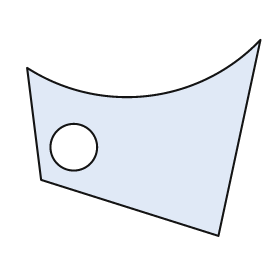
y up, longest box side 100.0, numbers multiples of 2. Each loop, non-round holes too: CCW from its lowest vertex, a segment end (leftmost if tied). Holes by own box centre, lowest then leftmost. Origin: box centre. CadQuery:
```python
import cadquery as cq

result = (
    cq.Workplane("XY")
    .moveTo(32.0, -42.0)
    .lineTo(50.0, 42.0)
    .threePointArc((2.0, 18.0), (-50.0, 30.0))
    .lineTo(-44.0, -18.0)
    .close()
    .moveTo(-30.0, -4.0)
    .circle(10.0)
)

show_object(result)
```